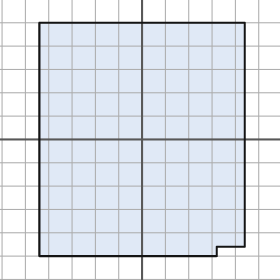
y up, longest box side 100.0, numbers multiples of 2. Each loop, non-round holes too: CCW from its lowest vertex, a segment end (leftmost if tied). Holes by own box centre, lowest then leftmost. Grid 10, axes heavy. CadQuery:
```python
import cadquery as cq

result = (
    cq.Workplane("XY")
    .moveTo(-44.0, -50.0)
    .lineTo(32.0, -50.0)
    .lineTo(32.0, -46.0)
    .lineTo(44.0, -46.0)
    .lineTo(44.0, 50.0)
    .lineTo(-44.0, 50.0)
    .close()
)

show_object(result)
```